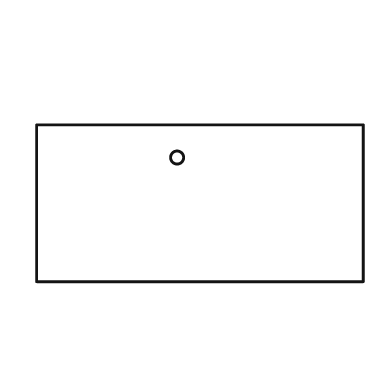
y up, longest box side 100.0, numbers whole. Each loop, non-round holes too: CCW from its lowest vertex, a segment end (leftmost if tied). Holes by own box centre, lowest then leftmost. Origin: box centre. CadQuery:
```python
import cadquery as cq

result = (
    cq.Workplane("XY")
    .moveTo(-50.0, -24.0)
    .lineTo(50.0, -24.0)
    .lineTo(50.0, 24.0)
    .lineTo(-50.0, 24.0)
    .close()
    .moveTo(-7.0, 14.0)
    .circle(2.0)
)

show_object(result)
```